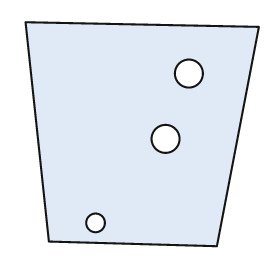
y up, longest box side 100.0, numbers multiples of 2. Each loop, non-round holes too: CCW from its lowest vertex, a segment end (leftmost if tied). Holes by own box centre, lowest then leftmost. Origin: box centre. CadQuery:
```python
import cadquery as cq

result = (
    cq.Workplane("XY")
    .moveTo(32.0, -48.0)
    .lineTo(50.0, 46.0)
    .lineTo(-50.0, 48.0)
    .lineTo(-40.0, -46.0)
    .close()
    .moveTo(-20.0, -38.0)
    .circle(4.0)
    .moveTo(10.0, -2.0)
    .circle(6.0)
    .moveTo(20.0, 26.0)
    .circle(6.0)
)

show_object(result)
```